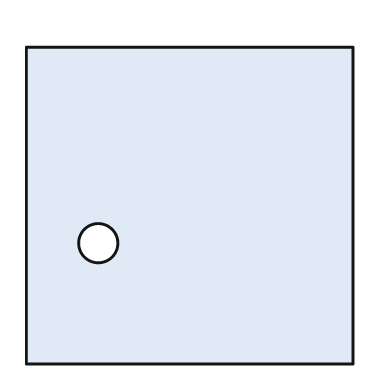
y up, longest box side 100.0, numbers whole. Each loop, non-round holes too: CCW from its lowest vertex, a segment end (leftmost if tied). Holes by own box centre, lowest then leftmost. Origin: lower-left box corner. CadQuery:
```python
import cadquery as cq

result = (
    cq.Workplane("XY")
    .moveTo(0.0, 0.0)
    .lineTo(100.0, 0.0)
    .lineTo(100.0, 97.0)
    .lineTo(0.0, 97.0)
    .close()
    .moveTo(22.0, 37.0)
    .circle(6.0)
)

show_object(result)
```